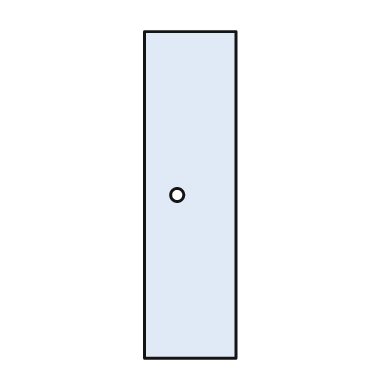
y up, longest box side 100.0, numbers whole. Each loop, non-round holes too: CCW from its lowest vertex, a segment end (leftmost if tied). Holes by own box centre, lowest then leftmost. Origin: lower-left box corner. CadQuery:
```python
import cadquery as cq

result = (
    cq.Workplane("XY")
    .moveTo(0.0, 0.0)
    .lineTo(28.0, 0.0)
    .lineTo(28.0, 100.0)
    .lineTo(0.0, 100.0)
    .close()
    .moveTo(10.0, 50.0)
    .circle(2.0)
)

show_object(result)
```